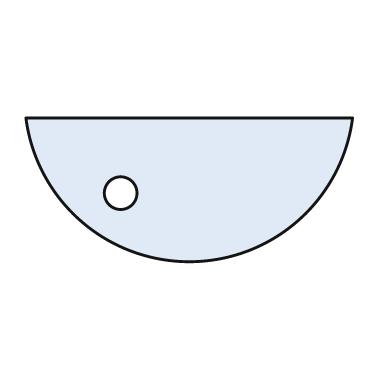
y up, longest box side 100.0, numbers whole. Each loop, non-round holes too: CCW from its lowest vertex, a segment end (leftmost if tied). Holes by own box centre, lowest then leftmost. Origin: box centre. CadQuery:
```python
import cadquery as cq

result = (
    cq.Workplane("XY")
    .moveTo(-50.0, 22.0)
    .threePointArc((0.0, -22.0), (50.0, 22.0))
    .close()
    .moveTo(-21.0, -1.0)
    .circle(5.0)
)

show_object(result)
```